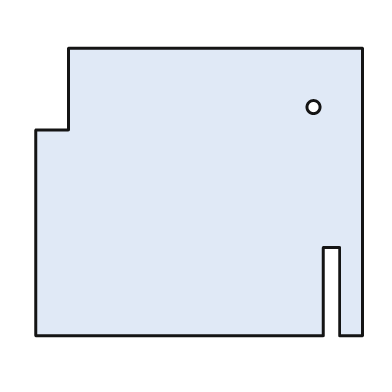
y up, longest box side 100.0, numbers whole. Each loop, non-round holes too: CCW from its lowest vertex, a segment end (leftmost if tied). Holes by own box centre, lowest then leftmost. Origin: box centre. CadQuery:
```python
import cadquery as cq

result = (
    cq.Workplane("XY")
    .moveTo(-50.0, -44.0)
    .lineTo(38.0, -44.0)
    .lineTo(38.0, -17.0)
    .lineTo(43.0, -17.0)
    .lineTo(43.0, -44.0)
    .lineTo(50.0, -44.0)
    .lineTo(50.0, 44.0)
    .lineTo(-40.0, 44.0)
    .lineTo(-40.0, 19.0)
    .lineTo(-50.0, 19.0)
    .close()
    .moveTo(35.0, 26.0)
    .circle(2.0)
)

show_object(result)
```